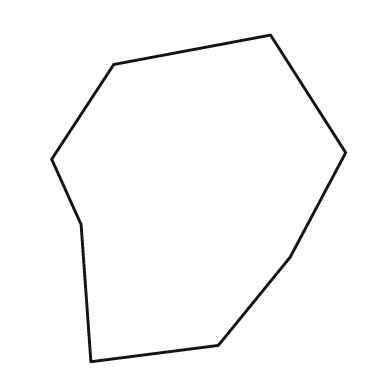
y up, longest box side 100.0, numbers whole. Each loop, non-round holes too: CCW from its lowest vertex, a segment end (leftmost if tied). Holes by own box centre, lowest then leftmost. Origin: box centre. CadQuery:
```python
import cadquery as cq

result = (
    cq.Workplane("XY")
    .moveTo(-33.0, -50.0)
    .lineTo(6.0, -45.0)
    .lineTo(28.0, -18.0)
    .lineTo(45.0, 14.0)
    .lineTo(22.0, 50.0)
    .lineTo(-26.0, 41.0)
    .lineTo(-45.0, 12.0)
    .lineTo(-36.0, -8.0)
    .close()
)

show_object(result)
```